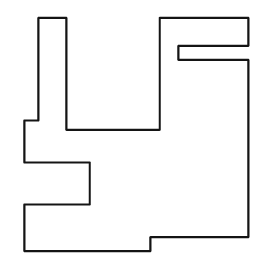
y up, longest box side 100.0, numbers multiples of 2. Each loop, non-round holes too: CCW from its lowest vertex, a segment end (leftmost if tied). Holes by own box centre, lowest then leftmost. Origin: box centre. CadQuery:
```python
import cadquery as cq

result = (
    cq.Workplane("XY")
    .moveTo(-48.0, -50.0)
    .lineTo(6.0, -50.0)
    .lineTo(6.0, -44.0)
    .lineTo(48.0, -44.0)
    .lineTo(48.0, 32.0)
    .lineTo(18.0, 32.0)
    .lineTo(18.0, 38.0)
    .lineTo(48.0, 38.0)
    .lineTo(48.0, 50.0)
    .lineTo(10.0, 50.0)
    .lineTo(10.0, 2.0)
    .lineTo(-30.0, 2.0)
    .lineTo(-30.0, 50.0)
    .lineTo(-42.0, 50.0)
    .lineTo(-42.0, 6.0)
    .lineTo(-48.0, 6.0)
    .lineTo(-48.0, -12.0)
    .lineTo(-20.0, -12.0)
    .lineTo(-20.0, -30.0)
    .lineTo(-48.0, -30.0)
    .close()
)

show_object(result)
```